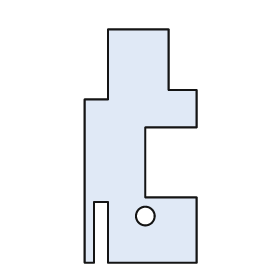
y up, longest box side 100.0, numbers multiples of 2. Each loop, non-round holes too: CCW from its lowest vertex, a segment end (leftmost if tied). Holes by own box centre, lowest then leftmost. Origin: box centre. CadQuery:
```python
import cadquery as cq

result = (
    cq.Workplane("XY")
    .moveTo(-24.0, -50.0)
    .lineTo(-20.0, -50.0)
    .lineTo(-20.0, -24.0)
    .lineTo(-14.0, -24.0)
    .lineTo(-14.0, -50.0)
    .lineTo(24.0, -50.0)
    .lineTo(24.0, -22.0)
    .lineTo(2.0, -22.0)
    .lineTo(2.0, 8.0)
    .lineTo(24.0, 8.0)
    .lineTo(24.0, 24.0)
    .lineTo(12.0, 24.0)
    .lineTo(12.0, 50.0)
    .lineTo(-14.0, 50.0)
    .lineTo(-14.0, 20.0)
    .lineTo(-24.0, 20.0)
    .close()
    .moveTo(2.0, -30.0)
    .circle(4.0)
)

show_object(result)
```